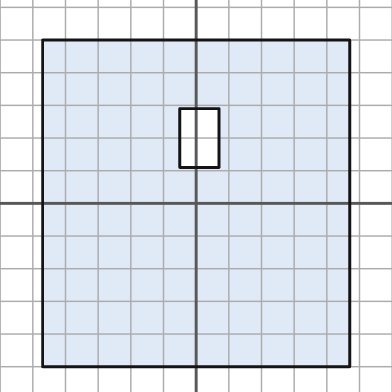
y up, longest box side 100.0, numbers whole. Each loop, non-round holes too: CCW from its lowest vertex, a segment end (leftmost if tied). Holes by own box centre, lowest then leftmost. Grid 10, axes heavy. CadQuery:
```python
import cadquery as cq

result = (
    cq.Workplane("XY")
    .moveTo(-47.0, -50.0)
    .lineTo(47.0, -50.0)
    .lineTo(47.0, 50.0)
    .lineTo(-47.0, 50.0)
    .close()
    .moveTo(-5.0, 11.0)
    .lineTo(7.0, 11.0)
    .lineTo(7.0, 29.0)
    .lineTo(-5.0, 29.0)
    .close()
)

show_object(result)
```